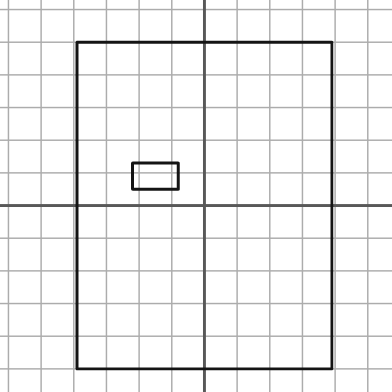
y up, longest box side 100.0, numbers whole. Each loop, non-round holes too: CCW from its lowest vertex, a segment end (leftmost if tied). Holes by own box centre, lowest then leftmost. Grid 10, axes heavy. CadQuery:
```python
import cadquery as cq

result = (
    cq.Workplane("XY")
    .moveTo(-39.0, -50.0)
    .lineTo(39.0, -50.0)
    .lineTo(39.0, 50.0)
    .lineTo(-39.0, 50.0)
    .close()
    .moveTo(-22.0, 5.0)
    .lineTo(-8.0, 5.0)
    .lineTo(-8.0, 13.0)
    .lineTo(-22.0, 13.0)
    .close()
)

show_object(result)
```